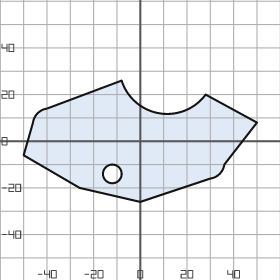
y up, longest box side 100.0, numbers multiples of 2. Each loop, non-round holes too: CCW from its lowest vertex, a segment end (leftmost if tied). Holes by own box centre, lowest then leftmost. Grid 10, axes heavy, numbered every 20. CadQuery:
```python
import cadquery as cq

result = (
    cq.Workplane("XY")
    .moveTo(0.0, -26.0)
    .lineTo(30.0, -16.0)
    .threePointArc((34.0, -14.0), (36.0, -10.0))
    .lineTo(50.0, 8.0)
    .lineTo(28.0, 20.0)
    .threePointArc((8.0, 12.0), (-8.0, 26.0))
    .lineTo(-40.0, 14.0)
    .threePointArc((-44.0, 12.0), (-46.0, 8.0))
    .lineTo(-50.0, -6.0)
    .lineTo(-26.0, -20.0)
    .close()
    .moveTo(-12.0, -14.0)
    .circle(4.0)
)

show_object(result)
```